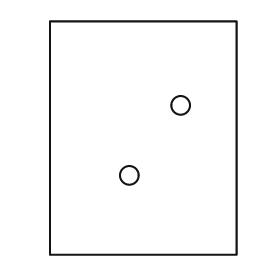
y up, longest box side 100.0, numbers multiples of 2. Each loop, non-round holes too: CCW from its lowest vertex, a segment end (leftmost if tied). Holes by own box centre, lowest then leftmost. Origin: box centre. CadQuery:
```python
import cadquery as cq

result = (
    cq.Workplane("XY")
    .moveTo(-40.0, -50.0)
    .lineTo(40.0, -50.0)
    .lineTo(40.0, 50.0)
    .lineTo(-40.0, 50.0)
    .close()
    .moveTo(-6.0, -16.0)
    .circle(4.0)
    .moveTo(16.0, 14.0)
    .circle(4.0)
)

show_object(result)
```